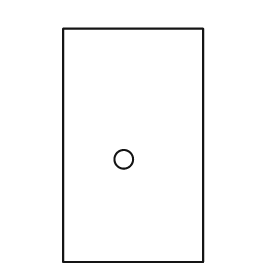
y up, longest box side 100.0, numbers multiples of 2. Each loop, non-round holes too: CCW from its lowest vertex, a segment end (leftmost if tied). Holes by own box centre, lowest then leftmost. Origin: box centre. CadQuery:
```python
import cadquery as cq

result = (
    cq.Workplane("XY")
    .moveTo(-30.0, -50.0)
    .lineTo(30.0, -50.0)
    .lineTo(30.0, 50.0)
    .lineTo(-30.0, 50.0)
    .close()
    .moveTo(-4.0, -6.0)
    .circle(4.0)
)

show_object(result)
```